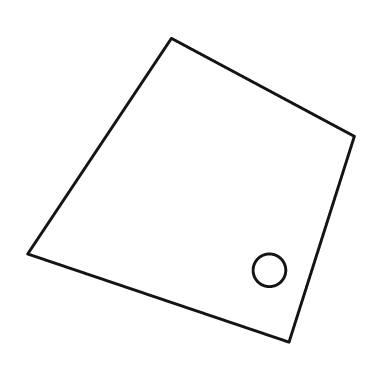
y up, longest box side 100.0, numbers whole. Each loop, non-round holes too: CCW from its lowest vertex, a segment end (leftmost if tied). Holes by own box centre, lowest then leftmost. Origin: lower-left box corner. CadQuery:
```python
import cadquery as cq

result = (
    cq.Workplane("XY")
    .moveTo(80.0, 0.0)
    .lineTo(100.0, 63.0)
    .lineTo(44.0, 93.0)
    .lineTo(0.0, 27.0)
    .close()
    .moveTo(74.0, 22.0)
    .circle(5.0)
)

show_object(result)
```